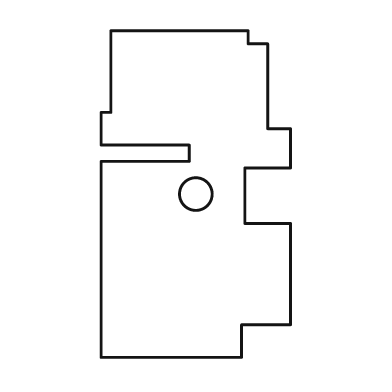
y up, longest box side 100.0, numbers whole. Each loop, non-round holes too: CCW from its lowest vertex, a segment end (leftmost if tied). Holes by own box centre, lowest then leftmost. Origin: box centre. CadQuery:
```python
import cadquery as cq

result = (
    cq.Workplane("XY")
    .moveTo(-29.0, -50.0)
    .lineTo(14.0, -50.0)
    .lineTo(14.0, -40.0)
    .lineTo(29.0, -40.0)
    .lineTo(29.0, -9.0)
    .lineTo(15.0, -9.0)
    .lineTo(15.0, 8.0)
    .lineTo(29.0, 8.0)
    .lineTo(29.0, 20.0)
    .lineTo(22.0, 20.0)
    .lineTo(22.0, 46.0)
    .lineTo(16.0, 46.0)
    .lineTo(16.0, 50.0)
    .lineTo(-26.0, 50.0)
    .lineTo(-26.0, 25.0)
    .lineTo(-29.0, 25.0)
    .lineTo(-29.0, 15.0)
    .lineTo(-2.0, 15.0)
    .lineTo(-2.0, 10.0)
    .lineTo(-29.0, 10.0)
    .close()
    .moveTo(0.0, 0.0)
    .circle(5.0)
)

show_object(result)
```